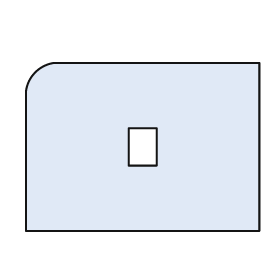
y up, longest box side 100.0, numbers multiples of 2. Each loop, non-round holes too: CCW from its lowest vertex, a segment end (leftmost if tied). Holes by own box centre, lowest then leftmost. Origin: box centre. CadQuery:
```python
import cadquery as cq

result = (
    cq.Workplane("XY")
    .moveTo(-50.0, -36.0)
    .lineTo(50.0, -36.0)
    .lineTo(50.0, 36.0)
    .lineTo(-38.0, 36.0)
    .threePointArc((-46.0, 32.0), (-50.0, 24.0))
    .close()
    .moveTo(-6.0, -8.0)
    .lineTo(6.0, -8.0)
    .lineTo(6.0, 8.0)
    .lineTo(-6.0, 8.0)
    .close()
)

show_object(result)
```